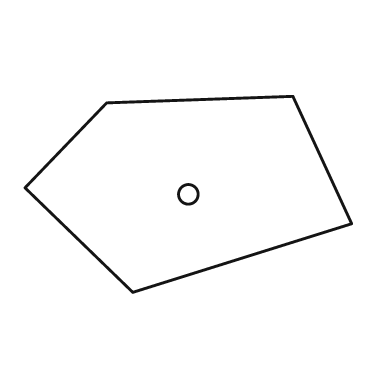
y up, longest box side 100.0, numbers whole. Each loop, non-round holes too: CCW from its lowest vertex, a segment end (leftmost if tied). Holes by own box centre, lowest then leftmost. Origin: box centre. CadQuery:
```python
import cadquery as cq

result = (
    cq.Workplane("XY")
    .moveTo(-17.0, -30.0)
    .lineTo(50.0, -9.0)
    .lineTo(32.0, 30.0)
    .lineTo(-25.0, 28.0)
    .lineTo(-50.0, 2.0)
    .close()
    .moveTo(0.0, 0.0)
    .circle(3.0)
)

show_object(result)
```